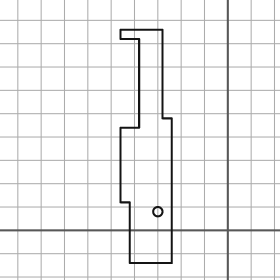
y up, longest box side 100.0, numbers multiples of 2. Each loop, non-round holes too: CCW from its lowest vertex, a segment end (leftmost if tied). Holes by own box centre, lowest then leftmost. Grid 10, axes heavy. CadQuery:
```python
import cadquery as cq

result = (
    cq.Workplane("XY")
    .moveTo(-42.0, -14.0)
    .lineTo(-24.0, -14.0)
    .lineTo(-24.0, 48.0)
    .lineTo(-28.0, 48.0)
    .lineTo(-28.0, 86.0)
    .lineTo(-46.0, 86.0)
    .lineTo(-46.0, 82.0)
    .lineTo(-38.0, 82.0)
    .lineTo(-38.0, 44.0)
    .lineTo(-46.0, 44.0)
    .lineTo(-46.0, 12.0)
    .lineTo(-42.0, 12.0)
    .close()
    .moveTo(-30.0, 8.0)
    .circle(2.0)
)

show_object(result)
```